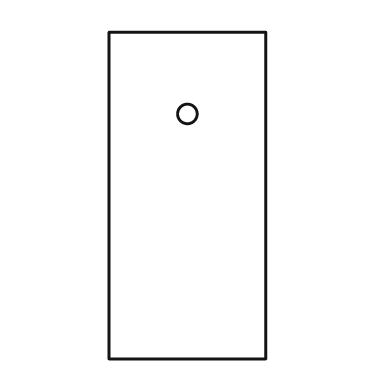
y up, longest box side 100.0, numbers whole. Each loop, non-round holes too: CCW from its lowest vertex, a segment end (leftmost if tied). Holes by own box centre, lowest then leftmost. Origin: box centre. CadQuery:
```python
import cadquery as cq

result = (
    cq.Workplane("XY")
    .moveTo(-24.0, -50.0)
    .lineTo(24.0, -50.0)
    .lineTo(24.0, 50.0)
    .lineTo(-24.0, 50.0)
    .close()
    .moveTo(0.0, 25.0)
    .circle(3.0)
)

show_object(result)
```